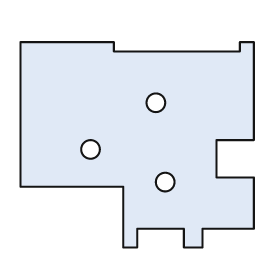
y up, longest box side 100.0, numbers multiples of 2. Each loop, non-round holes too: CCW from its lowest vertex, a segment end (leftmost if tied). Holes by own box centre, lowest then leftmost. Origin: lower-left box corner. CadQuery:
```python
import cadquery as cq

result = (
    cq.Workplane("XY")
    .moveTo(44.0, 0.0)
    .lineTo(50.0, 0.0)
    .lineTo(50.0, 8.0)
    .lineTo(70.0, 8.0)
    .lineTo(70.0, 0.0)
    .lineTo(78.0, 0.0)
    .lineTo(78.0, 8.0)
    .lineTo(100.0, 8.0)
    .lineTo(100.0, 30.0)
    .lineTo(84.0, 30.0)
    .lineTo(84.0, 46.0)
    .lineTo(100.0, 46.0)
    .lineTo(100.0, 88.0)
    .lineTo(94.0, 88.0)
    .lineTo(94.0, 84.0)
    .lineTo(40.0, 84.0)
    .lineTo(40.0, 88.0)
    .lineTo(0.0, 88.0)
    .lineTo(0.0, 26.0)
    .lineTo(44.0, 26.0)
    .close()
    .moveTo(62.0, 28.0)
    .circle(4.0)
    .moveTo(30.0, 42.0)
    .circle(4.0)
    .moveTo(58.0, 62.0)
    .circle(4.0)
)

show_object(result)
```